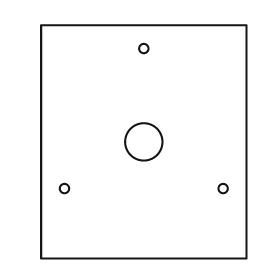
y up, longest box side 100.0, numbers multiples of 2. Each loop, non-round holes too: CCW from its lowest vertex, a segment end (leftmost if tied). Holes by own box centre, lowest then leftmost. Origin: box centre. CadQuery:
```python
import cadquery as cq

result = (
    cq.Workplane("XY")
    .moveTo(-44.0, -50.0)
    .lineTo(44.0, -50.0)
    .lineTo(44.0, 50.0)
    .lineTo(-44.0, 50.0)
    .close()
    .moveTo(-34.0, -20.0)
    .circle(2.0)
    .moveTo(34.0, -20.0)
    .circle(2.0)
    .moveTo(0.0, 0.0)
    .circle(8.0)
    .moveTo(0.0, 40.0)
    .circle(2.0)
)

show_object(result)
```